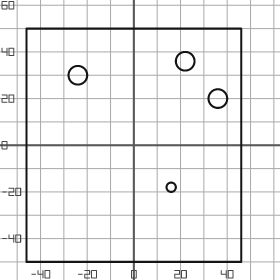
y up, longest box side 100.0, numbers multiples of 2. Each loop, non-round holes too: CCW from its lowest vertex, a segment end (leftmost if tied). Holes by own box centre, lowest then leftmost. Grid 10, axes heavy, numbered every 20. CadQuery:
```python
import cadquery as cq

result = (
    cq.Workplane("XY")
    .moveTo(-46.0, -50.0)
    .lineTo(46.0, -50.0)
    .lineTo(46.0, 50.0)
    .lineTo(-46.0, 50.0)
    .close()
    .moveTo(16.0, -18.0)
    .circle(2.0)
    .moveTo(36.0, 20.0)
    .circle(4.0)
    .moveTo(-24.0, 30.0)
    .circle(4.0)
    .moveTo(22.0, 36.0)
    .circle(4.0)
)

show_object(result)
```